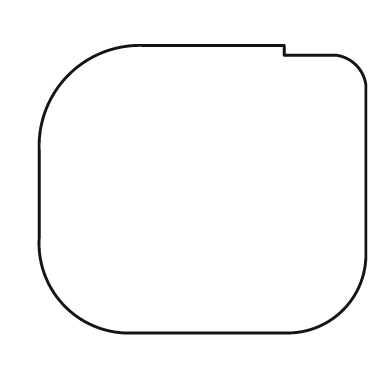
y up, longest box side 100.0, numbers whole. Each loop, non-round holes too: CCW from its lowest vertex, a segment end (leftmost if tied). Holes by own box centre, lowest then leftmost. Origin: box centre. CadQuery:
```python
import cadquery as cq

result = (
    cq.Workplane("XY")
    .moveTo(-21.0, -44.0)
    .lineTo(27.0, -44.0)
    .threePointArc((43.0, -37.0), (50.0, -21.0))
    .lineTo(50.0, 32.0)
    .threePointArc((47.0, 38.0), (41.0, 41.0))
    .lineTo(25.0, 41.0)
    .lineTo(25.0, 44.0)
    .lineTo(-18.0, 44.0)
    .threePointArc((-41.0, 35.0), (-50.0, 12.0))
    .lineTo(-50.0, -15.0)
    .threePointArc((-42.0, -36.0), (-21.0, -44.0))
    .close()
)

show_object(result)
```